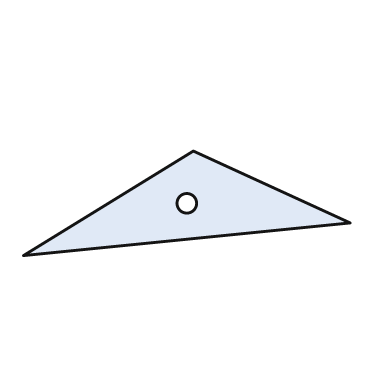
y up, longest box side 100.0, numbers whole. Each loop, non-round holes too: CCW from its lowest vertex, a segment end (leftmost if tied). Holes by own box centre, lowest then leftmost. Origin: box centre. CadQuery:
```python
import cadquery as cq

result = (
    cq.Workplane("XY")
    .moveTo(-50.0, -16.0)
    .lineTo(50.0, -6.0)
    .lineTo(2.0, 16.0)
    .close()
    .moveTo(0.0, 0.0)
    .circle(3.0)
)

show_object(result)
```